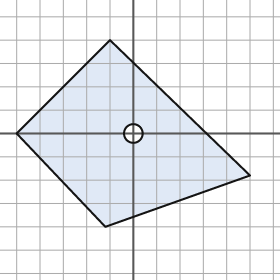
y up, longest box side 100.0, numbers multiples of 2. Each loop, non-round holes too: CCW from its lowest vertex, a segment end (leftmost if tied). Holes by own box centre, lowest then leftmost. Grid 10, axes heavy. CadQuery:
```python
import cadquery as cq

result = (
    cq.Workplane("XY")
    .moveTo(-12.0, -40.0)
    .lineTo(50.0, -18.0)
    .lineTo(-10.0, 40.0)
    .lineTo(-50.0, 0.0)
    .close()
    .moveTo(0.0, 0.0)
    .circle(4.0)
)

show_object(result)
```